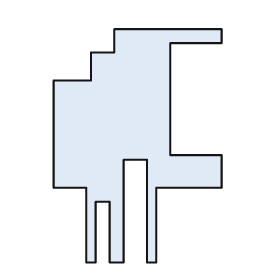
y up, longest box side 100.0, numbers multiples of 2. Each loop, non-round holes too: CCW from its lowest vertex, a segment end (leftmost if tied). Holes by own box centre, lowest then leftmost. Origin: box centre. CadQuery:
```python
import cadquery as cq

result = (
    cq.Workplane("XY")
    .moveTo(-22.0, -50.0)
    .lineTo(-18.0, -50.0)
    .lineTo(-18.0, -24.0)
    .lineTo(-12.0, -24.0)
    .lineTo(-12.0, -50.0)
    .lineTo(-6.0, -50.0)
    .lineTo(-6.0, -6.0)
    .lineTo(4.0, -6.0)
    .lineTo(4.0, -50.0)
    .lineTo(8.0, -50.0)
    .lineTo(8.0, -18.0)
    .lineTo(36.0, -18.0)
    .lineTo(36.0, -4.0)
    .lineTo(14.0, -4.0)
    .lineTo(14.0, 44.0)
    .lineTo(36.0, 44.0)
    .lineTo(36.0, 50.0)
    .lineTo(-10.0, 50.0)
    .lineTo(-10.0, 40.0)
    .lineTo(-20.0, 40.0)
    .lineTo(-20.0, 28.0)
    .lineTo(-36.0, 28.0)
    .lineTo(-36.0, -18.0)
    .lineTo(-22.0, -18.0)
    .close()
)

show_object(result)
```